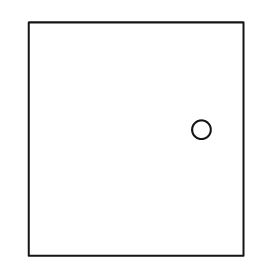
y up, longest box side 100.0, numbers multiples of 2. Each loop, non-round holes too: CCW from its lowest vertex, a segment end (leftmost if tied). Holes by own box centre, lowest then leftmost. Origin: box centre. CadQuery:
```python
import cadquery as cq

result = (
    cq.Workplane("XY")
    .moveTo(-46.0, -50.0)
    .lineTo(46.0, -50.0)
    .lineTo(46.0, 50.0)
    .lineTo(-46.0, 50.0)
    .close()
    .moveTo(28.0, 4.0)
    .circle(4.0)
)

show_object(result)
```